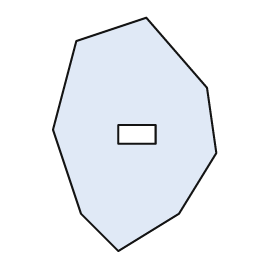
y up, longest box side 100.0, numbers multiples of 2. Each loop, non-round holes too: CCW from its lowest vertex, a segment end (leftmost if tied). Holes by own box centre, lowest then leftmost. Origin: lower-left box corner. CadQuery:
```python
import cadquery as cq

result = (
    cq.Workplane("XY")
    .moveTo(28.0, 0.0)
    .lineTo(54.0, 16.0)
    .lineTo(70.0, 42.0)
    .lineTo(66.0, 70.0)
    .lineTo(40.0, 100.0)
    .lineTo(10.0, 90.0)
    .lineTo(0.0, 52.0)
    .lineTo(12.0, 16.0)
    .close()
    .moveTo(28.0, 46.0)
    .lineTo(44.0, 46.0)
    .lineTo(44.0, 54.0)
    .lineTo(28.0, 54.0)
    .close()
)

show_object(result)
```